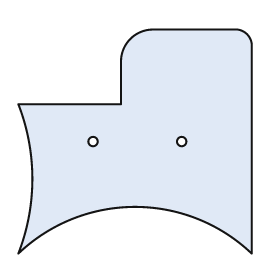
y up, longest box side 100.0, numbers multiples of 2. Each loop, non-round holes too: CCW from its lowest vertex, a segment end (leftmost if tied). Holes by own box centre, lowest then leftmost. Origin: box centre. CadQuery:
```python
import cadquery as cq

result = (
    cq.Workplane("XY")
    .moveTo(-50.0, -48.0)
    .threePointArc((0.0, -28.0), (50.0, -48.0))
    .lineTo(50.0, 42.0)
    .threePointArc((48.0, 46.0), (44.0, 48.0))
    .lineTo(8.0, 48.0)
    .threePointArc((-2.0, 44.0), (-6.0, 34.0))
    .lineTo(-6.0, 16.0)
    .lineTo(-50.0, 16.0)
    .threePointArc((-44.0, -16.0), (-50.0, -48.0))
    .close()
    .moveTo(-18.0, 0.0)
    .circle(2.0)
    .moveTo(20.0, 0.0)
    .circle(2.0)
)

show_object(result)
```